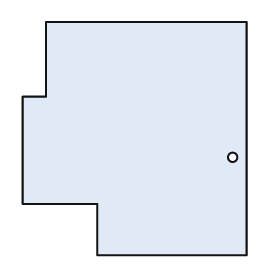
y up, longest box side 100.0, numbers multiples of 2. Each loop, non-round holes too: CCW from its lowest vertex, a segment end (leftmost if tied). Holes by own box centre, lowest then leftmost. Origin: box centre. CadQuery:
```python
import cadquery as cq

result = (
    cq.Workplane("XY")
    .moveTo(-16.0, -50.0)
    .lineTo(48.0, -50.0)
    .lineTo(48.0, 50.0)
    .lineTo(-38.0, 50.0)
    .lineTo(-38.0, 18.0)
    .lineTo(-48.0, 18.0)
    .lineTo(-48.0, -28.0)
    .lineTo(-16.0, -28.0)
    .close()
    .moveTo(42.0, -8.0)
    .circle(2.0)
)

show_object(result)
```